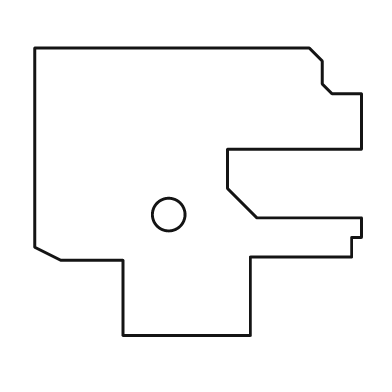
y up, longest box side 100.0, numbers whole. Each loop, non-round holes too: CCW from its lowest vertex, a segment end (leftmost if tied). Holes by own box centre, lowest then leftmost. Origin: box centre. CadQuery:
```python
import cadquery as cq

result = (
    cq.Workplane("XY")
    .moveTo(-23.0, -44.0)
    .lineTo(16.0, -44.0)
    .lineTo(16.0, -20.0)
    .lineTo(47.0, -20.0)
    .lineTo(47.0, -14.0)
    .lineTo(50.0, -14.0)
    .lineTo(50.0, -8.0)
    .lineTo(18.0, -8.0)
    .lineTo(9.0, 1.0)
    .lineTo(9.0, 13.0)
    .lineTo(50.0, 13.0)
    .lineTo(50.0, 30.0)
    .lineTo(41.0, 30.0)
    .lineTo(38.0, 33.0)
    .lineTo(38.0, 40.0)
    .lineTo(34.0, 44.0)
    .lineTo(-50.0, 44.0)
    .lineTo(-50.0, -17.0)
    .lineTo(-42.0, -21.0)
    .lineTo(-23.0, -21.0)
    .close()
    .moveTo(-9.0, -7.0)
    .circle(5.0)
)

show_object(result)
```